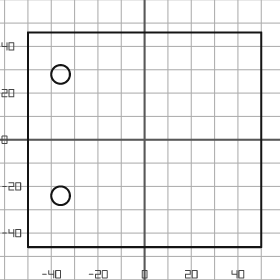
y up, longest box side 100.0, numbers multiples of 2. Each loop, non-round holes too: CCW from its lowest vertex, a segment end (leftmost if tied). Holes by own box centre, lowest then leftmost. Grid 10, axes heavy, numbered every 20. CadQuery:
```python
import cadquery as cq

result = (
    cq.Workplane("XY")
    .moveTo(-50.0, -46.0)
    .lineTo(50.0, -46.0)
    .lineTo(50.0, 46.0)
    .lineTo(-50.0, 46.0)
    .close()
    .moveTo(-36.0, -24.0)
    .circle(4.0)
    .moveTo(-36.0, 28.0)
    .circle(4.0)
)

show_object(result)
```